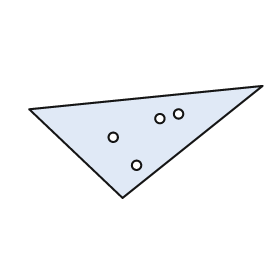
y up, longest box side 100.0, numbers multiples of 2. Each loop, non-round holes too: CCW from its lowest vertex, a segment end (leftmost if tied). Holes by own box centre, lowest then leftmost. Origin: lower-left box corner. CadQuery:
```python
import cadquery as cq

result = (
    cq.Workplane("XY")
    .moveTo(40.0, 0.0)
    .lineTo(100.0, 48.0)
    .lineTo(0.0, 38.0)
    .close()
    .moveTo(46.0, 14.0)
    .circle(2.0)
    .moveTo(36.0, 26.0)
    .circle(2.0)
    .moveTo(56.0, 34.0)
    .circle(2.0)
    .moveTo(64.0, 36.0)
    .circle(2.0)
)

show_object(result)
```